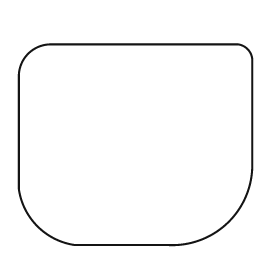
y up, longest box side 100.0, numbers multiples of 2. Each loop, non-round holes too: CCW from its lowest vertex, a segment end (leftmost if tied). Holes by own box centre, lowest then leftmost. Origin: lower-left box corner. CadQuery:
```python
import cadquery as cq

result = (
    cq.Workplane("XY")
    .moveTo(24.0, 0.0)
    .lineTo(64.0, 0.0)
    .threePointArc((90.0, 10.0), (100.0, 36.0))
    .lineTo(100.0, 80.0)
    .threePointArc((98.0, 84.0), (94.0, 86.0))
    .lineTo(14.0, 86.0)
    .threePointArc((4.0, 82.0), (0.0, 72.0))
    .lineTo(0.0, 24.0)
    .threePointArc((8.0, 8.0), (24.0, 0.0))
    .close()
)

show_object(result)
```